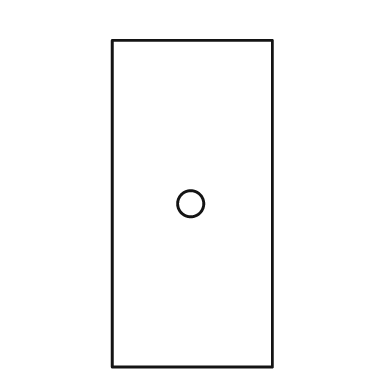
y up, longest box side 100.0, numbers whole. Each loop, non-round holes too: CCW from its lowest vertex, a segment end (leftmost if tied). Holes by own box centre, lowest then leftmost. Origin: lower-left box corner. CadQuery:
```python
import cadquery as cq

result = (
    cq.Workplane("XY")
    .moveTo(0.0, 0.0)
    .lineTo(49.0, 0.0)
    .lineTo(49.0, 100.0)
    .lineTo(0.0, 100.0)
    .close()
    .moveTo(24.0, 50.0)
    .circle(4.0)
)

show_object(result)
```